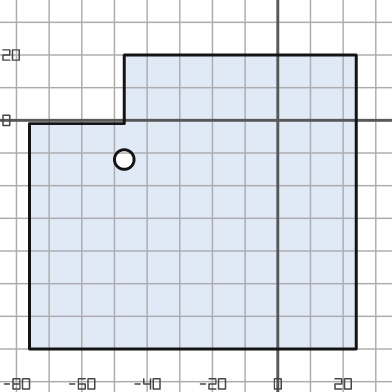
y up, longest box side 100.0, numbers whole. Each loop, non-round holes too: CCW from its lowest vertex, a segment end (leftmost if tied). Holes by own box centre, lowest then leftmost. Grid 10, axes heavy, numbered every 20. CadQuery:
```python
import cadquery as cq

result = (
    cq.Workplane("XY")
    .moveTo(-76.0, -70.0)
    .lineTo(24.0, -70.0)
    .lineTo(24.0, 20.0)
    .lineTo(-47.0, 20.0)
    .lineTo(-47.0, -1.0)
    .lineTo(-76.0, -1.0)
    .close()
    .moveTo(-47.0, -12.0)
    .circle(3.0)
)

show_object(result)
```